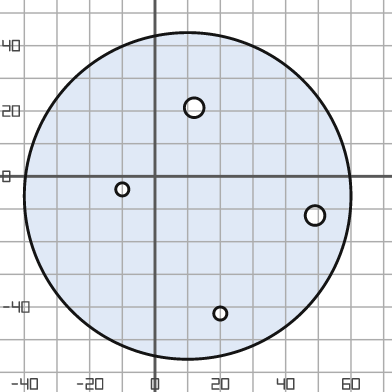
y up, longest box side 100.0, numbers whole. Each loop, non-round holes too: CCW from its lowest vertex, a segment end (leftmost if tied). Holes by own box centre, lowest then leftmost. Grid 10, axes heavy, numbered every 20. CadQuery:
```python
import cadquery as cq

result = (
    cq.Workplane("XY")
    .moveTo(10.0, -6.0)
    .circle(50.0)
    .moveTo(20.0, -42.0)
    .circle(2.0)
    .moveTo(49.0, -12.0)
    .circle(3.0)
    .moveTo(-10.0, -4.0)
    .circle(2.0)
    .moveTo(12.0, 21.0)
    .circle(3.0)
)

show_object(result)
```